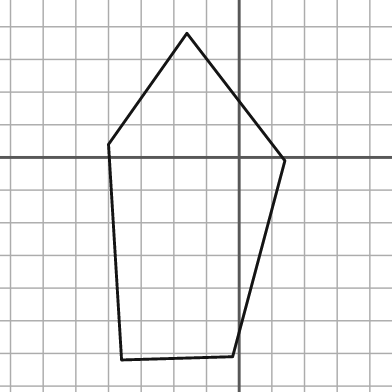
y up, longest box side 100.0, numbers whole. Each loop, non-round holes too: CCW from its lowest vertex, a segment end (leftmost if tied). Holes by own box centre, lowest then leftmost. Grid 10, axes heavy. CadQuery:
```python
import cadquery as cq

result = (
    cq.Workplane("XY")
    .moveTo(-36.0, -62.0)
    .lineTo(-2.0, -61.0)
    .lineTo(14.0, -1.0)
    .lineTo(-16.0, 38.0)
    .lineTo(-40.0, 4.0)
    .close()
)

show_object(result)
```